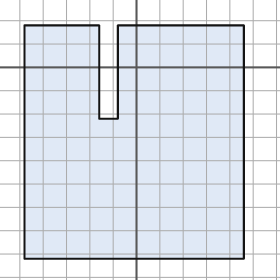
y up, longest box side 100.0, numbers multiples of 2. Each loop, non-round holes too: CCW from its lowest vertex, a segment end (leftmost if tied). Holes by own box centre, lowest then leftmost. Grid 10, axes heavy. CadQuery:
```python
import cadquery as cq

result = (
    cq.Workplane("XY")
    .moveTo(-48.0, -82.0)
    .lineTo(46.0, -82.0)
    .lineTo(46.0, 18.0)
    .lineTo(-8.0, 18.0)
    .lineTo(-8.0, -22.0)
    .lineTo(-16.0, -22.0)
    .lineTo(-16.0, 18.0)
    .lineTo(-48.0, 18.0)
    .close()
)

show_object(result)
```